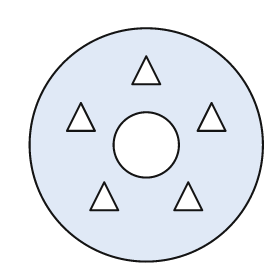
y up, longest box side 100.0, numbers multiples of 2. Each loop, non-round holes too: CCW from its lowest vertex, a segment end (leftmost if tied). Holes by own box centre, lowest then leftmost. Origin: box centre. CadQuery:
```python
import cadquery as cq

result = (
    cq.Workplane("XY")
    .moveTo(0.0, 0.0)
    .circle(50.0)
    .moveTo(-24.0, -28.0)
    .lineTo(-12.0, -28.0)
    .lineTo(-18.0, -16.0)
    .close()
    .moveTo(12.0, -28.0)
    .lineTo(24.0, -28.0)
    .lineTo(18.0, -16.0)
    .close()
    .moveTo(0.0, 0.0)
    .circle(14.0)
    .moveTo(-34.0, 6.0)
    .lineTo(-22.0, 6.0)
    .lineTo(-28.0, 18.0)
    .close()
    .moveTo(22.0, 6.0)
    .lineTo(34.0, 6.0)
    .lineTo(28.0, 18.0)
    .close()
    .moveTo(-6.0, 26.0)
    .lineTo(6.0, 26.0)
    .lineTo(0.0, 38.0)
    .close()
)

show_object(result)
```